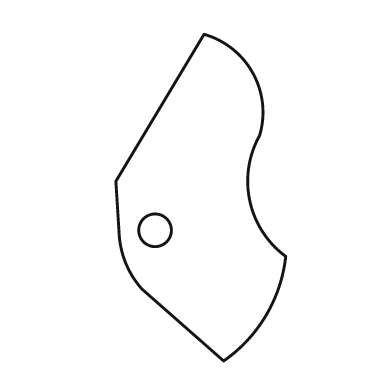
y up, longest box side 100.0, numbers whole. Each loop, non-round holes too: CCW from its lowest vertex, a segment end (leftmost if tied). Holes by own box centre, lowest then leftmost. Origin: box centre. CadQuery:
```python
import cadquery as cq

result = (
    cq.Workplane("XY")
    .moveTo(7.0, -50.0)
    .threePointArc((20.0, -36.0), (26.0, -18.0))
    .threePointArc((15.0, -1.0), (18.0, 19.0))
    .threePointArc((16.0, 38.0), (1.0, 50.0))
    .lineTo(-26.0, 5.0)
    .lineTo(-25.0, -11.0)
    .threePointArc((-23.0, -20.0), (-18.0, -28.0))
    .close()
    .moveTo(-14.0, -10.0)
    .circle(5.0)
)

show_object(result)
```